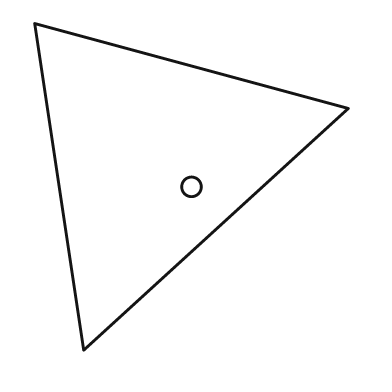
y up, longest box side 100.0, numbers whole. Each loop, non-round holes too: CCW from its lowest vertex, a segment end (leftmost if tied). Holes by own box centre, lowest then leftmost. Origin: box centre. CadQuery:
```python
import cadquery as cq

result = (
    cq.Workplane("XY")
    .moveTo(-33.0, -50.0)
    .lineTo(48.0, 24.0)
    .lineTo(-48.0, 50.0)
    .close()
    .moveTo(0.0, 0.0)
    .circle(3.0)
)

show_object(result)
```